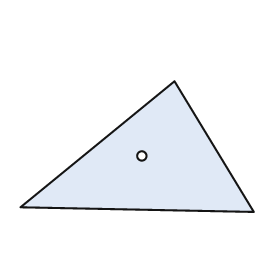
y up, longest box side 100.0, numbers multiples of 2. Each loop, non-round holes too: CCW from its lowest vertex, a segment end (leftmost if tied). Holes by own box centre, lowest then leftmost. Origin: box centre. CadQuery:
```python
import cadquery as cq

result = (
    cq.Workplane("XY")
    .moveTo(50.0, -28.0)
    .lineTo(16.0, 28.0)
    .lineTo(-50.0, -26.0)
    .close()
    .moveTo(2.0, -4.0)
    .circle(2.0)
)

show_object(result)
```